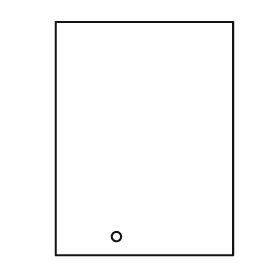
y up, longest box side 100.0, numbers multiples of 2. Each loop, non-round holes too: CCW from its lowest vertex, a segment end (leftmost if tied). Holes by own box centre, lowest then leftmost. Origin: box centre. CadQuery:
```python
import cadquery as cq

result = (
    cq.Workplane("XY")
    .moveTo(-38.0, -50.0)
    .lineTo(38.0, -50.0)
    .lineTo(38.0, 50.0)
    .lineTo(-38.0, 50.0)
    .close()
    .moveTo(-12.0, -42.0)
    .circle(2.0)
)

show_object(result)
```